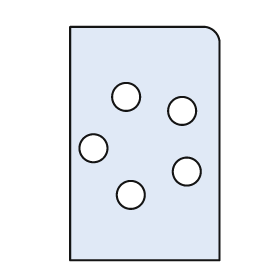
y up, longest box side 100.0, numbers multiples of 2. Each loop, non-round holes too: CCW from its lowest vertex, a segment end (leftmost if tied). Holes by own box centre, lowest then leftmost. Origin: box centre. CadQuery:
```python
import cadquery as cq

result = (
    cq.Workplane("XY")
    .moveTo(-32.0, -50.0)
    .lineTo(32.0, -50.0)
    .lineTo(32.0, 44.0)
    .threePointArc((30.0, 48.0), (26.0, 50.0))
    .lineTo(-32.0, 50.0)
    .close()
    .moveTo(-6.0, -22.0)
    .circle(6.0)
    .moveTo(18.0, -12.0)
    .circle(6.0)
    .moveTo(-22.0, -2.0)
    .circle(6.0)
    .moveTo(16.0, 14.0)
    .circle(6.0)
    .moveTo(-8.0, 20.0)
    .circle(6.0)
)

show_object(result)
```